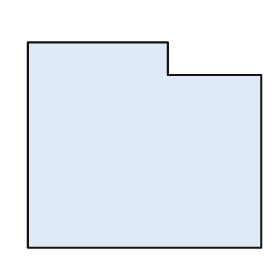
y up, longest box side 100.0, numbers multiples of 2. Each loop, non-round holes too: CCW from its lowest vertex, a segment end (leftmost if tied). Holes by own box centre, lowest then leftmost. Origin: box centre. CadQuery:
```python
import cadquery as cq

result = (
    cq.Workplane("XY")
    .moveTo(-50.0, -44.0)
    .lineTo(50.0, -44.0)
    .lineTo(50.0, 30.0)
    .lineTo(10.0, 30.0)
    .lineTo(10.0, 44.0)
    .lineTo(-50.0, 44.0)
    .close()
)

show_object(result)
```